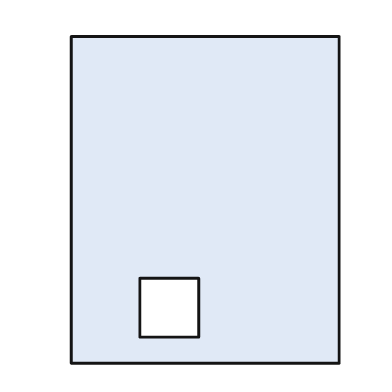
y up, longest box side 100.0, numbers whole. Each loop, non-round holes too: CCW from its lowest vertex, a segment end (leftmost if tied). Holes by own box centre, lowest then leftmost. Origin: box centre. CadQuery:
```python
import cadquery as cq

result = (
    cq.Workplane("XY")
    .moveTo(-41.0, -50.0)
    .lineTo(41.0, -50.0)
    .lineTo(41.0, 50.0)
    .lineTo(-41.0, 50.0)
    .close()
    .moveTo(-20.0, -42.0)
    .lineTo(-2.0, -42.0)
    .lineTo(-2.0, -24.0)
    .lineTo(-20.0, -24.0)
    .close()
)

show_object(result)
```